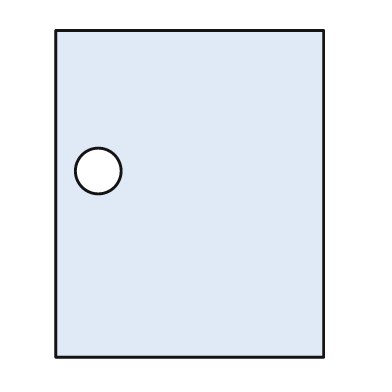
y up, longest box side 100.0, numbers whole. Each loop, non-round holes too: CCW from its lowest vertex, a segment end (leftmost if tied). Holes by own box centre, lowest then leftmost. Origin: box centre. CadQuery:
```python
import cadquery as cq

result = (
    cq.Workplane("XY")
    .moveTo(-41.0, -50.0)
    .lineTo(41.0, -50.0)
    .lineTo(41.0, 50.0)
    .lineTo(-41.0, 50.0)
    .close()
    .moveTo(-28.0, 7.0)
    .circle(7.0)
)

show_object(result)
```